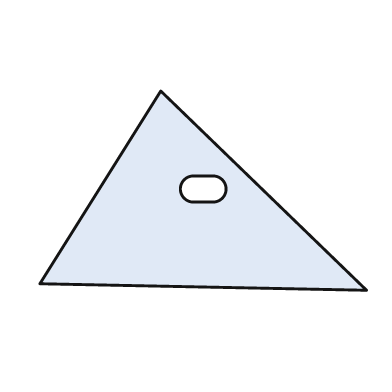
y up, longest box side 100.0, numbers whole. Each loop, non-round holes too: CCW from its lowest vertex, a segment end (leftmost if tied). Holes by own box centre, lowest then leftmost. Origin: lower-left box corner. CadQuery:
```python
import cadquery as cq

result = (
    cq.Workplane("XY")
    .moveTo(100.0, 0.0)
    .lineTo(37.0, 61.0)
    .lineTo(0.0, 2.0)
    .close()
    .moveTo(47.0, 27.0)
    .lineTo(53.0, 27.0)
    .threePointArc((57.0, 31.0), (53.0, 35.0))
    .lineTo(47.0, 35.0)
    .threePointArc((43.0, 31.0), (47.0, 27.0))
    .close()
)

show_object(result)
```